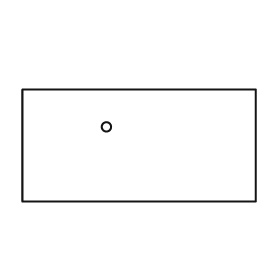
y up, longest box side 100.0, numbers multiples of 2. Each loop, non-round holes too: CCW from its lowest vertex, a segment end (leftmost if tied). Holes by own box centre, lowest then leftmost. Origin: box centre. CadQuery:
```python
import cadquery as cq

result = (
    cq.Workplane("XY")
    .moveTo(-50.0, -24.0)
    .lineTo(50.0, -24.0)
    .lineTo(50.0, 24.0)
    .lineTo(-50.0, 24.0)
    .close()
    .moveTo(-14.0, 8.0)
    .circle(2.0)
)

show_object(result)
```